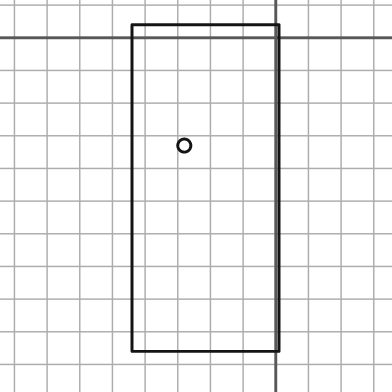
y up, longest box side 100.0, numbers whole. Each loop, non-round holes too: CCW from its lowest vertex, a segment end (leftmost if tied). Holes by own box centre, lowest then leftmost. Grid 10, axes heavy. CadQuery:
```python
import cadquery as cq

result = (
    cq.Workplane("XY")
    .moveTo(-44.0, -96.0)
    .lineTo(1.0, -96.0)
    .lineTo(1.0, 4.0)
    .lineTo(-44.0, 4.0)
    .close()
    .moveTo(-28.0, -33.0)
    .circle(2.0)
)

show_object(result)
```